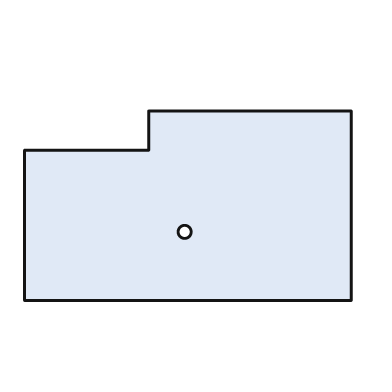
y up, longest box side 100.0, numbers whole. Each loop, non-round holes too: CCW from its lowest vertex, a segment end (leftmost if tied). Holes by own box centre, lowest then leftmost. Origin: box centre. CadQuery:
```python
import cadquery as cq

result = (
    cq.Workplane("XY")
    .moveTo(-50.0, -29.0)
    .lineTo(50.0, -29.0)
    .lineTo(50.0, 29.0)
    .lineTo(-12.0, 29.0)
    .lineTo(-12.0, 17.0)
    .lineTo(-50.0, 17.0)
    .close()
    .moveTo(-1.0, -8.0)
    .circle(2.0)
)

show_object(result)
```